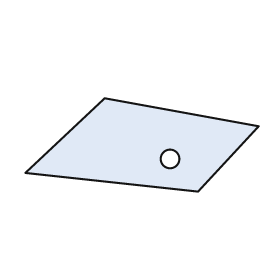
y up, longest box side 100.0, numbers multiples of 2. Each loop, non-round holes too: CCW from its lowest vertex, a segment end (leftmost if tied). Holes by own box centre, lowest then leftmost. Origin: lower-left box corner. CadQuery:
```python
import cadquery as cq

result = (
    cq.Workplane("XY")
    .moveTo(74.0, 0.0)
    .lineTo(100.0, 28.0)
    .lineTo(34.0, 40.0)
    .lineTo(0.0, 8.0)
    .close()
    .moveTo(62.0, 14.0)
    .circle(4.0)
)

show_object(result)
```